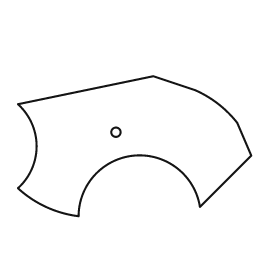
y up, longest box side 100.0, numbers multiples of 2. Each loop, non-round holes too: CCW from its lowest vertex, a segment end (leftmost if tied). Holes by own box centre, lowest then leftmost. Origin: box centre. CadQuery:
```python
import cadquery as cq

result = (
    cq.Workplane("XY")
    .moveTo(-24.0, -30.0)
    .threePointArc((0.0, -4.0), (28.0, -26.0))
    .lineTo(50.0, -4.0)
    .lineTo(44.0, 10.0)
    .threePointArc((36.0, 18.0), (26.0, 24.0))
    .lineTo(8.0, 30.0)
    .lineTo(-50.0, 18.0)
    .threePointArc((-42.0, 0.0), (-50.0, -18.0))
    .threePointArc((-38.0, -26.0), (-24.0, -30.0))
    .close()
    .moveTo(-8.0, 6.0)
    .circle(2.0)
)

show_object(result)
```